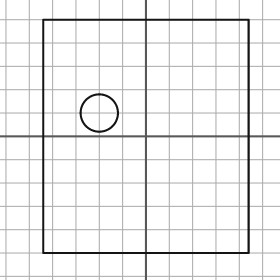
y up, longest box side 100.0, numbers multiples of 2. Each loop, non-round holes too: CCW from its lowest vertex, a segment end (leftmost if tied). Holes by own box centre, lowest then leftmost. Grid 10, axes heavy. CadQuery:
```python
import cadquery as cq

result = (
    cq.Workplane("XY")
    .moveTo(-44.0, -50.0)
    .lineTo(44.0, -50.0)
    .lineTo(44.0, 50.0)
    .lineTo(-44.0, 50.0)
    .close()
    .moveTo(-20.0, 10.0)
    .circle(8.0)
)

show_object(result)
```